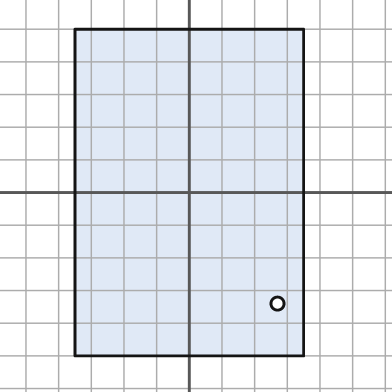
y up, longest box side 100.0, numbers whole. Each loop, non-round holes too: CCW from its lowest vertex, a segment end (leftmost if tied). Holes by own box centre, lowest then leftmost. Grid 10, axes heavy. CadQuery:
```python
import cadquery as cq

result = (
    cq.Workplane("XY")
    .moveTo(-35.0, -50.0)
    .lineTo(35.0, -50.0)
    .lineTo(35.0, 50.0)
    .lineTo(-35.0, 50.0)
    .close()
    .moveTo(27.0, -34.0)
    .circle(2.0)
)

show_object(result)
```